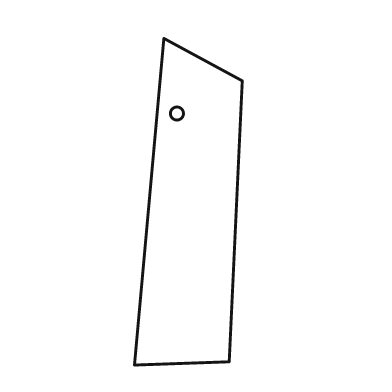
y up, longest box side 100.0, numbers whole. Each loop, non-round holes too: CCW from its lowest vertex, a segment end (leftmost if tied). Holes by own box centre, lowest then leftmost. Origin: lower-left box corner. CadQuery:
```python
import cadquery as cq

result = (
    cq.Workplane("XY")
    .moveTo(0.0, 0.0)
    .lineTo(29.0, 1.0)
    .lineTo(33.0, 87.0)
    .lineTo(9.0, 100.0)
    .close()
    .moveTo(13.0, 77.0)
    .circle(2.0)
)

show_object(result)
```